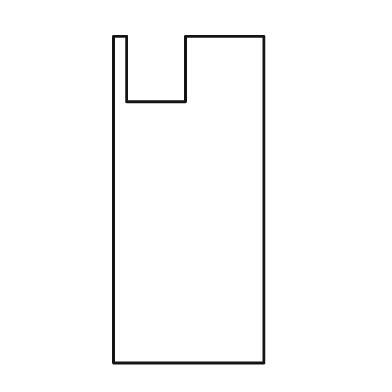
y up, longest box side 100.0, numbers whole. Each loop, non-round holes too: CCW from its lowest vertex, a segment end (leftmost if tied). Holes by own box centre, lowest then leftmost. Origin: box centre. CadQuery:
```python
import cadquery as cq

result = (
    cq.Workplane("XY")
    .moveTo(-23.0, -50.0)
    .lineTo(23.0, -50.0)
    .lineTo(23.0, 50.0)
    .lineTo(-1.0, 50.0)
    .lineTo(-1.0, 30.0)
    .lineTo(-19.0, 30.0)
    .lineTo(-19.0, 50.0)
    .lineTo(-23.0, 50.0)
    .close()
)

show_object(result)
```